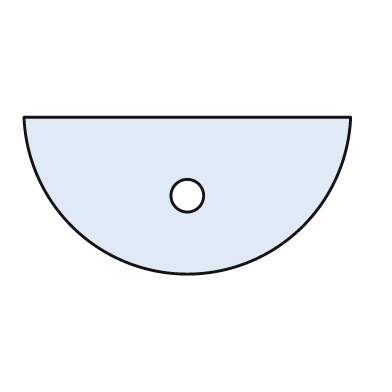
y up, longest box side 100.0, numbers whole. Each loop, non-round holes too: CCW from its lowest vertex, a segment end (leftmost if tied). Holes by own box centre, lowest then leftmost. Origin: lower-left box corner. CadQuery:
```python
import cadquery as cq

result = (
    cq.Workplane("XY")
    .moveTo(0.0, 48.0)
    .threePointArc((50.0, 0.0), (100.0, 48.0))
    .close()
    .moveTo(50.0, 24.0)
    .circle(5.0)
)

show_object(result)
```